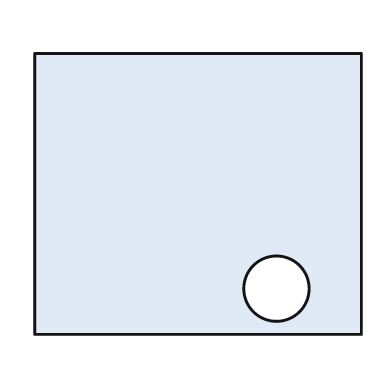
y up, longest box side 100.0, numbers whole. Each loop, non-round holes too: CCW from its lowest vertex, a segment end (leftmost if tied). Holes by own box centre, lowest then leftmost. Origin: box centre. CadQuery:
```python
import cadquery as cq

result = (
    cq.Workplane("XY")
    .moveTo(-50.0, -43.0)
    .lineTo(50.0, -43.0)
    .lineTo(50.0, 43.0)
    .lineTo(-50.0, 43.0)
    .close()
    .moveTo(24.0, -29.0)
    .circle(10.0)
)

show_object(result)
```